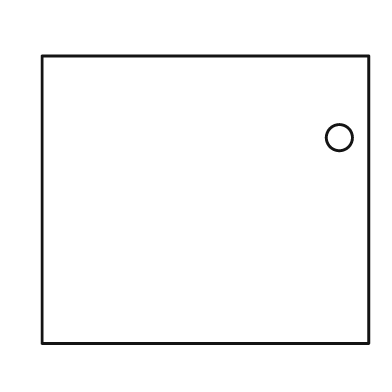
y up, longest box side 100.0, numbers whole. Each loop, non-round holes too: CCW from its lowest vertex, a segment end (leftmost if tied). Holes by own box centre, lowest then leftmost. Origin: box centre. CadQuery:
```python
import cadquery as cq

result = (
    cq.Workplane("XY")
    .moveTo(-50.0, -44.0)
    .lineTo(50.0, -44.0)
    .lineTo(50.0, 44.0)
    .lineTo(-50.0, 44.0)
    .close()
    .moveTo(41.0, 19.0)
    .circle(4.0)
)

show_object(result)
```